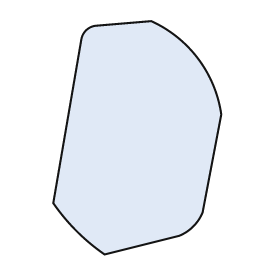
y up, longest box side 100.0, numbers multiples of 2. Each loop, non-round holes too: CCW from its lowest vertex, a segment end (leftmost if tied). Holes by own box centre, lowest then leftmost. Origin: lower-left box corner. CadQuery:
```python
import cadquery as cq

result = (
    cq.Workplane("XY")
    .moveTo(22.0, 0.0)
    .lineTo(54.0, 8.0)
    .threePointArc((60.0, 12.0), (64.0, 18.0))
    .lineTo(72.0, 60.0)
    .threePointArc((62.0, 84.0), (42.0, 100.0))
    .lineTo(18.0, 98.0)
    .threePointArc((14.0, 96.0), (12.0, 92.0))
    .lineTo(0.0, 22.0)
    .threePointArc((10.0, 10.0), (22.0, 0.0))
    .close()
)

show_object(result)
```